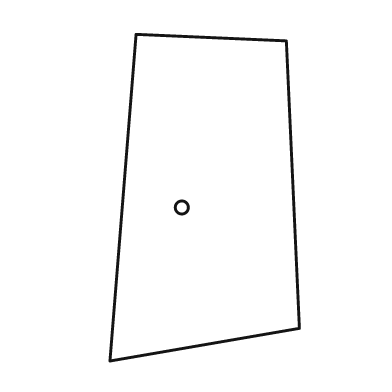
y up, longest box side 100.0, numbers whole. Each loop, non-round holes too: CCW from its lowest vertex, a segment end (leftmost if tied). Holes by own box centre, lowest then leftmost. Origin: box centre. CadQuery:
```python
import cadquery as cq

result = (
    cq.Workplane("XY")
    .moveTo(-29.0, -50.0)
    .lineTo(29.0, -40.0)
    .lineTo(25.0, 48.0)
    .lineTo(-21.0, 50.0)
    .close()
    .moveTo(-7.0, -3.0)
    .circle(2.0)
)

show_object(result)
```